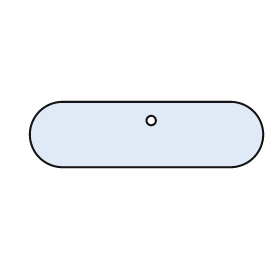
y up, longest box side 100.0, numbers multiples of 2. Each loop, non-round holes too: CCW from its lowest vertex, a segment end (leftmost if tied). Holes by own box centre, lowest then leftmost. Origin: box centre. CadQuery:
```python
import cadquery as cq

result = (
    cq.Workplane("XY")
    .moveTo(-36.0, -14.0)
    .lineTo(36.0, -14.0)
    .threePointArc((50.0, 0.0), (36.0, 14.0))
    .lineTo(-36.0, 14.0)
    .threePointArc((-50.0, 0.0), (-36.0, -14.0))
    .close()
    .moveTo(2.0, 6.0)
    .circle(2.0)
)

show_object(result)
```